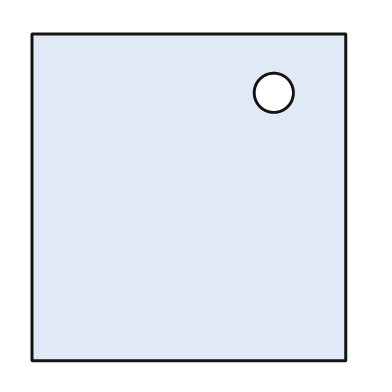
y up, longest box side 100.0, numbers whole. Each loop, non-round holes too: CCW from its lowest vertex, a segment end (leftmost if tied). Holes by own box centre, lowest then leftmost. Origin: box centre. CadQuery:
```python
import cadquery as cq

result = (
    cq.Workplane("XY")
    .moveTo(-48.0, -50.0)
    .lineTo(48.0, -50.0)
    .lineTo(48.0, 50.0)
    .lineTo(-48.0, 50.0)
    .close()
    .moveTo(26.0, 32.0)
    .circle(6.0)
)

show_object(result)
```